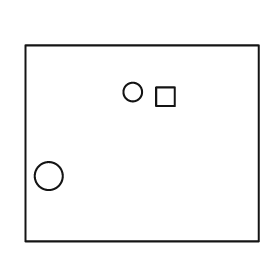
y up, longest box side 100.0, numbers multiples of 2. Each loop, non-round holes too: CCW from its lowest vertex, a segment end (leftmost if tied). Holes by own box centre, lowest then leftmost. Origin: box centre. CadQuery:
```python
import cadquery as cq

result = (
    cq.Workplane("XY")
    .moveTo(-50.0, -42.0)
    .lineTo(50.0, -42.0)
    .lineTo(50.0, 42.0)
    .lineTo(-50.0, 42.0)
    .close()
    .moveTo(-40.0, -14.0)
    .circle(6.0)
    .moveTo(6.0, 16.0)
    .lineTo(14.0, 16.0)
    .lineTo(14.0, 24.0)
    .lineTo(6.0, 24.0)
    .close()
    .moveTo(-4.0, 22.0)
    .circle(4.0)
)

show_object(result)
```